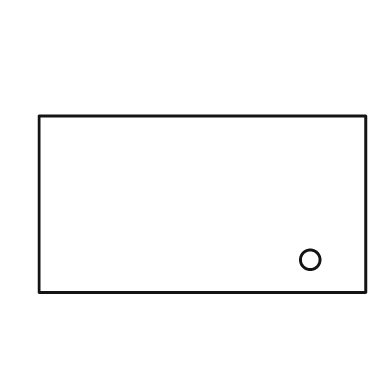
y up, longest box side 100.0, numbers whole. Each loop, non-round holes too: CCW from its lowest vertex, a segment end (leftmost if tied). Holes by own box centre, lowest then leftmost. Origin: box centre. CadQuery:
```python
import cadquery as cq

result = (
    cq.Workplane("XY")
    .moveTo(-50.0, -27.0)
    .lineTo(50.0, -27.0)
    .lineTo(50.0, 27.0)
    .lineTo(-50.0, 27.0)
    .close()
    .moveTo(33.0, -17.0)
    .circle(3.0)
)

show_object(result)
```